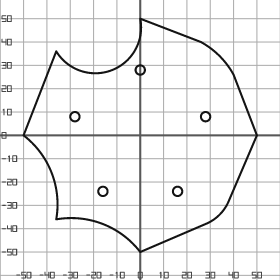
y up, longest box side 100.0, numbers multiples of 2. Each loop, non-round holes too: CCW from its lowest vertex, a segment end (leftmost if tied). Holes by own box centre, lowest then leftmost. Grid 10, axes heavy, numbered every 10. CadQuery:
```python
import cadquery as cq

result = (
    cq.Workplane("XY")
    .moveTo(0.0, -50.0)
    .lineTo(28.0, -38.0)
    .threePointArc((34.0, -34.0), (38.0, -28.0))
    .lineTo(50.0, 0.0)
    .lineTo(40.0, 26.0)
    .threePointArc((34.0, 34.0), (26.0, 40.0))
    .lineTo(0.0, 50.0)
    .threePointArc((-12.0, 28.0), (-36.0, 36.0))
    .lineTo(-50.0, 0.0)
    .threePointArc((-38.0, -16.0), (-36.0, -36.0))
    .threePointArc((-16.0, -38.0), (0.0, -50.0))
    .close()
    .moveTo(-16.0, -24.0)
    .circle(2.0)
    .moveTo(16.0, -24.0)
    .circle(2.0)
    .moveTo(-28.0, 8.0)
    .circle(2.0)
    .moveTo(28.0, 8.0)
    .circle(2.0)
    .moveTo(0.0, 28.0)
    .circle(2.0)
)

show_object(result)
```